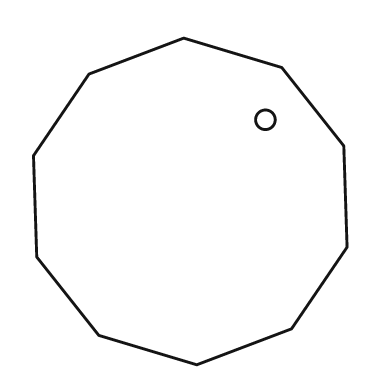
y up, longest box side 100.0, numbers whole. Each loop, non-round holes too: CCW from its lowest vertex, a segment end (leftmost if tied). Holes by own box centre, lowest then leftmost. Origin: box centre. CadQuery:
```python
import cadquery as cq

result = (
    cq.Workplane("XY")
    .moveTo(2.0, -50.0)
    .lineTo(31.0, -39.0)
    .lineTo(48.0, -14.0)
    .lineTo(47.0, 17.0)
    .lineTo(28.0, 41.0)
    .lineTo(-2.0, 50.0)
    .lineTo(-31.0, 39.0)
    .lineTo(-48.0, 14.0)
    .lineTo(-47.0, -17.0)
    .lineTo(-28.0, -41.0)
    .close()
    .moveTo(23.0, 25.0)
    .circle(3.0)
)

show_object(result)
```